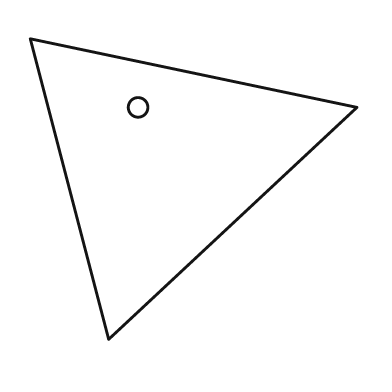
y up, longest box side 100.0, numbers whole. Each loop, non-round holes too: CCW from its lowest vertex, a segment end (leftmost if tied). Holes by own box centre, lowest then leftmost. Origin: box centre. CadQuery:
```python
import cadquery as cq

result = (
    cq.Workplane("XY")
    .moveTo(-26.0, -46.0)
    .lineTo(50.0, 25.0)
    .lineTo(-50.0, 46.0)
    .close()
    .moveTo(-17.0, 25.0)
    .circle(3.0)
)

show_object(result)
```